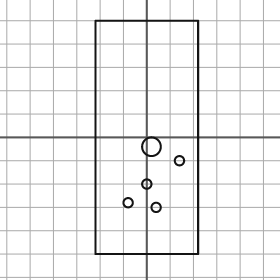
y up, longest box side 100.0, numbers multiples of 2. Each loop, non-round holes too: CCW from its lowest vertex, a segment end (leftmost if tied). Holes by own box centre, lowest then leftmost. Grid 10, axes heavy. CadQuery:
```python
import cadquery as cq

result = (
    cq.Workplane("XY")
    .moveTo(-22.0, -50.0)
    .lineTo(22.0, -50.0)
    .lineTo(22.0, 50.0)
    .lineTo(-22.0, 50.0)
    .close()
    .moveTo(4.0, -30.0)
    .circle(2.0)
    .moveTo(-8.0, -28.0)
    .circle(2.0)
    .moveTo(0.0, -20.0)
    .circle(2.0)
    .moveTo(14.0, -10.0)
    .circle(2.0)
    .moveTo(2.0, -4.0)
    .circle(4.0)
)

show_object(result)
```